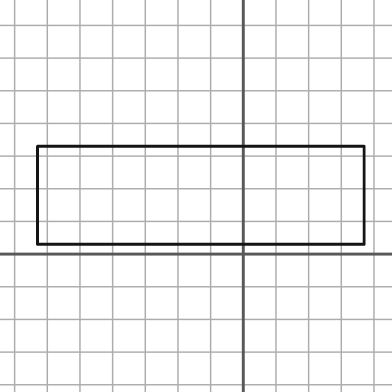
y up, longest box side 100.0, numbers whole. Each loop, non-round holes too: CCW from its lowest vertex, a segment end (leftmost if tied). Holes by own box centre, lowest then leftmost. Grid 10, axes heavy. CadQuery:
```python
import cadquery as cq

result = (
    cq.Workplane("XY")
    .moveTo(-63.0, 3.0)
    .lineTo(37.0, 3.0)
    .lineTo(37.0, 33.0)
    .lineTo(-63.0, 33.0)
    .close()
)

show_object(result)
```